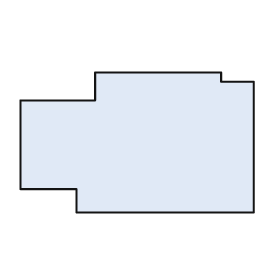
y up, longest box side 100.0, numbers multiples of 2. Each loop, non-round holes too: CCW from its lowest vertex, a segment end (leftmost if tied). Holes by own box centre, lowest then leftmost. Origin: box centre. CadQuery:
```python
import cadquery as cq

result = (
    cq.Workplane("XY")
    .moveTo(-26.0, -30.0)
    .lineTo(50.0, -30.0)
    .lineTo(50.0, 26.0)
    .lineTo(36.0, 26.0)
    .lineTo(36.0, 30.0)
    .lineTo(-18.0, 30.0)
    .lineTo(-18.0, 18.0)
    .lineTo(-50.0, 18.0)
    .lineTo(-50.0, -20.0)
    .lineTo(-26.0, -20.0)
    .close()
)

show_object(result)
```